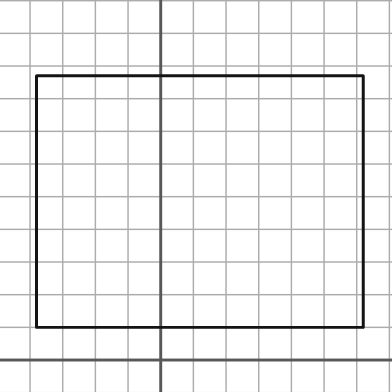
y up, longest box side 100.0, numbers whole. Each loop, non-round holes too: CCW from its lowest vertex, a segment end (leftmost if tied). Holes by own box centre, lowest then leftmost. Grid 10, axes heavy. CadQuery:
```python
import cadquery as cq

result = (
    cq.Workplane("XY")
    .moveTo(-38.0, 10.0)
    .lineTo(62.0, 10.0)
    .lineTo(62.0, 87.0)
    .lineTo(-38.0, 87.0)
    .close()
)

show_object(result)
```